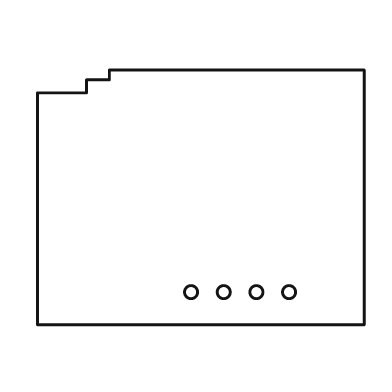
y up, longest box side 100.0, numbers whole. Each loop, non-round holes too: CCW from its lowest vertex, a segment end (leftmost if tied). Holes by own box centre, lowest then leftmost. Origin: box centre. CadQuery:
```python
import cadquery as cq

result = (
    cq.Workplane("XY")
    .moveTo(-50.0, -39.0)
    .lineTo(50.0, -39.0)
    .lineTo(50.0, 39.0)
    .lineTo(-28.0, 39.0)
    .lineTo(-28.0, 36.0)
    .lineTo(-35.0, 36.0)
    .lineTo(-35.0, 32.0)
    .lineTo(-50.0, 32.0)
    .close()
    .moveTo(-3.0, -29.0)
    .circle(2.0)
    .moveTo(7.0, -29.0)
    .circle(2.0)
    .moveTo(17.0, -29.0)
    .circle(2.0)
    .moveTo(27.0, -29.0)
    .circle(2.0)
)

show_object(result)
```